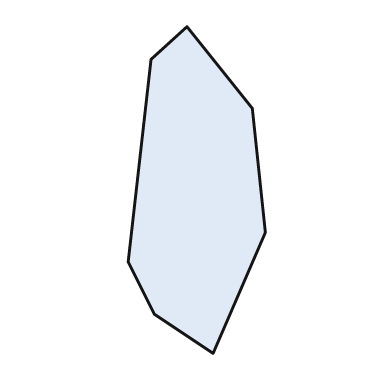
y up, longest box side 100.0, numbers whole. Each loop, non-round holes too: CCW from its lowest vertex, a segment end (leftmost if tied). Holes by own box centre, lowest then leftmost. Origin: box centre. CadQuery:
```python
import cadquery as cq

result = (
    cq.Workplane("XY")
    .moveTo(5.0, -50.0)
    .lineTo(21.0, -13.0)
    .lineTo(17.0, 25.0)
    .lineTo(-3.0, 50.0)
    .lineTo(-14.0, 40.0)
    .lineTo(-21.0, -22.0)
    .lineTo(-13.0, -38.0)
    .close()
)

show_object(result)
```